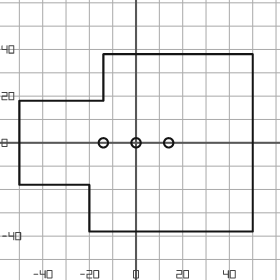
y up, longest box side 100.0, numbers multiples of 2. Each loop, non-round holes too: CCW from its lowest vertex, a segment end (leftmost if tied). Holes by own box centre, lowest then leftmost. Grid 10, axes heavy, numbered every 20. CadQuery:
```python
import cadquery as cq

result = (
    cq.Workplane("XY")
    .moveTo(-20.0, -38.0)
    .lineTo(50.0, -38.0)
    .lineTo(50.0, 38.0)
    .lineTo(-14.0, 38.0)
    .lineTo(-14.0, 18.0)
    .lineTo(-50.0, 18.0)
    .lineTo(-50.0, -18.0)
    .lineTo(-20.0, -18.0)
    .close()
    .moveTo(-14.0, 0.0)
    .circle(2.0)
    .moveTo(0.0, 0.0)
    .circle(2.0)
    .moveTo(14.0, 0.0)
    .circle(2.0)
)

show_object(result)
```